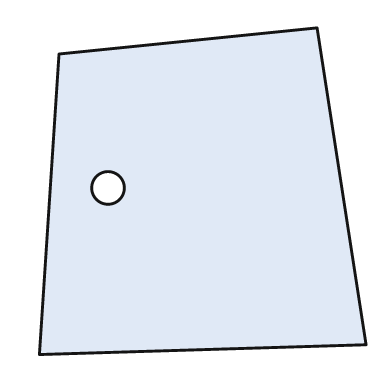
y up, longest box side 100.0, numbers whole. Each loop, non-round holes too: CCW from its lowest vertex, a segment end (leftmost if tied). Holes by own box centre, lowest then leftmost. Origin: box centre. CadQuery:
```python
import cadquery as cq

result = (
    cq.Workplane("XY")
    .moveTo(-50.0, -50.0)
    .lineTo(50.0, -47.0)
    .lineTo(35.0, 50.0)
    .lineTo(-44.0, 42.0)
    .close()
    .moveTo(-29.0, 1.0)
    .circle(5.0)
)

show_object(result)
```